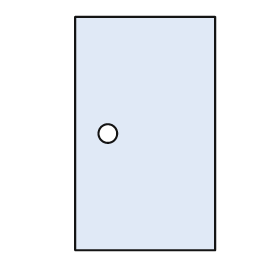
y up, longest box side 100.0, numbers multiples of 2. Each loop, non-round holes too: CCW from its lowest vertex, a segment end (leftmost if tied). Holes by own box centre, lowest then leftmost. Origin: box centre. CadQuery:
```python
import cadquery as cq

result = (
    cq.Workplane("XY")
    .moveTo(-30.0, -50.0)
    .lineTo(30.0, -50.0)
    .lineTo(30.0, 50.0)
    .lineTo(-30.0, 50.0)
    .close()
    .moveTo(-16.0, 0.0)
    .circle(4.0)
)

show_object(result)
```